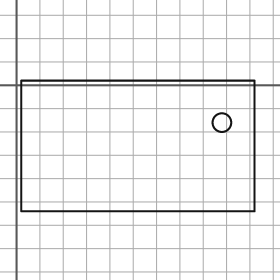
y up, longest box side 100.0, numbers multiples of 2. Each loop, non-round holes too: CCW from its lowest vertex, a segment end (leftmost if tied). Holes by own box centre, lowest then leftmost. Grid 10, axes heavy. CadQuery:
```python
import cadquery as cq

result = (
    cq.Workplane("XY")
    .moveTo(2.0, -54.0)
    .lineTo(102.0, -54.0)
    .lineTo(102.0, 2.0)
    .lineTo(2.0, 2.0)
    .close()
    .moveTo(88.0, -16.0)
    .circle(4.0)
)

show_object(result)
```